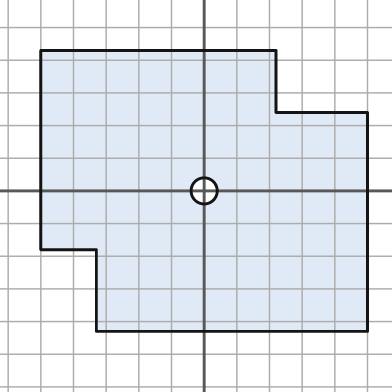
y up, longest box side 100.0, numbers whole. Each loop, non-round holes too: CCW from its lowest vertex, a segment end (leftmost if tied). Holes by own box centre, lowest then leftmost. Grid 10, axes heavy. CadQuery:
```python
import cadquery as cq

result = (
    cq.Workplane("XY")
    .moveTo(-33.0, -43.0)
    .lineTo(50.0, -43.0)
    .lineTo(50.0, 24.0)
    .lineTo(22.0, 24.0)
    .lineTo(22.0, 43.0)
    .lineTo(-50.0, 43.0)
    .lineTo(-50.0, -18.0)
    .lineTo(-33.0, -18.0)
    .close()
    .moveTo(0.0, 0.0)
    .circle(4.0)
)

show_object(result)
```